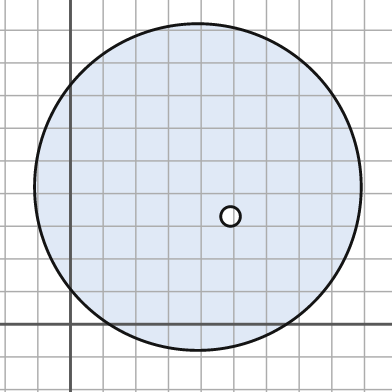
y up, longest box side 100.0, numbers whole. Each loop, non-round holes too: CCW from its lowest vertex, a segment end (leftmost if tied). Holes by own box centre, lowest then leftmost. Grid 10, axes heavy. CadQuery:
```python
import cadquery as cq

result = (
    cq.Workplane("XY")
    .moveTo(39.0, 42.0)
    .circle(50.0)
    .moveTo(49.0, 33.0)
    .circle(3.0)
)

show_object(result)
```